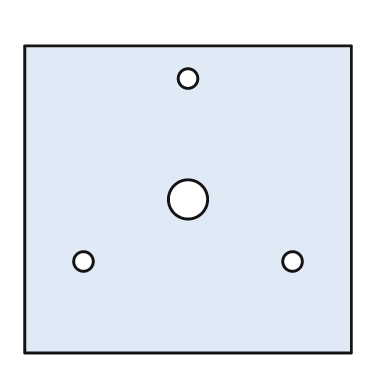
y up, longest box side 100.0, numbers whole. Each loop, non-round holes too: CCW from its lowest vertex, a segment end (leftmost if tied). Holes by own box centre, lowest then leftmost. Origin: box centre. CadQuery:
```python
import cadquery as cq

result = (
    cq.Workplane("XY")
    .moveTo(-50.0, -47.0)
    .lineTo(50.0, -47.0)
    .lineTo(50.0, 47.0)
    .lineTo(-50.0, 47.0)
    .close()
    .moveTo(-32.0, -19.0)
    .circle(3.0)
    .moveTo(32.0, -19.0)
    .circle(3.0)
    .moveTo(0.0, 0.0)
    .circle(6.0)
    .moveTo(0.0, 37.0)
    .circle(3.0)
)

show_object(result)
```